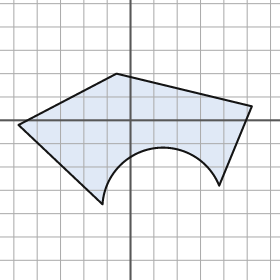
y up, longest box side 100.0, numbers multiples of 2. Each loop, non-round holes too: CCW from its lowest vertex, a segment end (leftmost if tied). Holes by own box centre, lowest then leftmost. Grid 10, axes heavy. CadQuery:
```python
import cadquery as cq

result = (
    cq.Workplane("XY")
    .moveTo(-12.0, -36.0)
    .threePointArc((10.0, -12.0), (38.0, -28.0))
    .lineTo(52.0, 6.0)
    .lineTo(-6.0, 20.0)
    .lineTo(-48.0, -2.0)
    .close()
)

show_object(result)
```